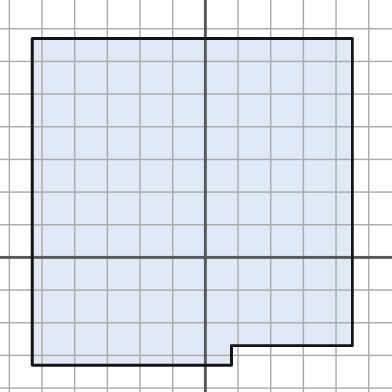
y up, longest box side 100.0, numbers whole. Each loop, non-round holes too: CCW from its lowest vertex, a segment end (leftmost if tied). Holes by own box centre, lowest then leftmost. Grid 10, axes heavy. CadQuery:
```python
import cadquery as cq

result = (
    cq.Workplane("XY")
    .moveTo(-53.0, -33.0)
    .lineTo(8.0, -33.0)
    .lineTo(8.0, -27.0)
    .lineTo(45.0, -27.0)
    .lineTo(45.0, 67.0)
    .lineTo(-53.0, 67.0)
    .close()
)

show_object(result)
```